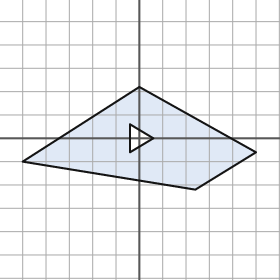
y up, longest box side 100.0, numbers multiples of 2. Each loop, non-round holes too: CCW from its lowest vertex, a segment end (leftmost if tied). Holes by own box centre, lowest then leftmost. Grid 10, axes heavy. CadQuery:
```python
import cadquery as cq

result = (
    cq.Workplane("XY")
    .moveTo(24.0, -22.0)
    .lineTo(50.0, -6.0)
    .lineTo(0.0, 22.0)
    .lineTo(-50.0, -10.0)
    .close()
    .moveTo(-4.0, -6.0)
    .lineTo(6.0, 0.0)
    .lineTo(-4.0, 6.0)
    .close()
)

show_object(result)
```